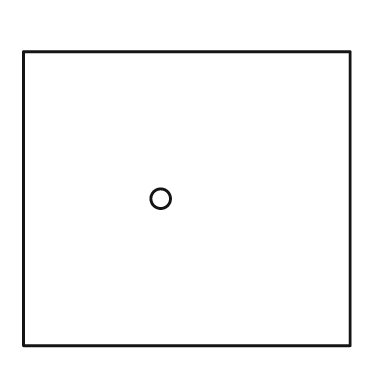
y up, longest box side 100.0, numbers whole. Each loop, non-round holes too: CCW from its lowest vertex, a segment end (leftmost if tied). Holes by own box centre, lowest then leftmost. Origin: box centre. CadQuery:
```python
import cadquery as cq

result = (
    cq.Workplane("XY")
    .moveTo(-50.0, -45.0)
    .lineTo(50.0, -45.0)
    .lineTo(50.0, 45.0)
    .lineTo(-50.0, 45.0)
    .close()
    .moveTo(-8.0, 0.0)
    .circle(3.0)
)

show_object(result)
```